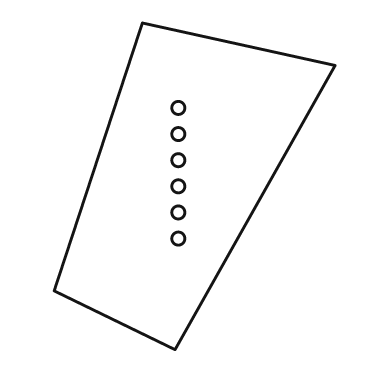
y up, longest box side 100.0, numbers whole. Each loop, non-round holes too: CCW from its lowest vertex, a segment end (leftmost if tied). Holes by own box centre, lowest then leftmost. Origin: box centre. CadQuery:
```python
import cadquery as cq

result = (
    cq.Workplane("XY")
    .moveTo(-6.0, -50.0)
    .lineTo(43.0, 37.0)
    .lineTo(-16.0, 50.0)
    .lineTo(-43.0, -32.0)
    .close()
    .moveTo(-5.0, -16.0)
    .circle(2.0)
    .moveTo(-5.0, -8.0)
    .circle(2.0)
    .moveTo(-5.0, 0.0)
    .circle(2.0)
    .moveTo(-5.0, 8.0)
    .circle(2.0)
    .moveTo(-5.0, 16.0)
    .circle(2.0)
    .moveTo(-5.0, 24.0)
    .circle(2.0)
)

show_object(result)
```